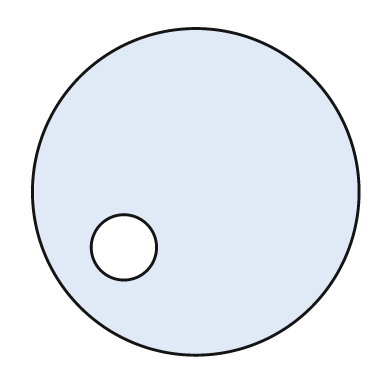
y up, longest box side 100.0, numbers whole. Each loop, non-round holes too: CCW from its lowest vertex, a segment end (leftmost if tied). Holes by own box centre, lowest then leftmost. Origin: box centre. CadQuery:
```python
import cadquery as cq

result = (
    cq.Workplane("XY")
    .moveTo(0.0, 0.0)
    .circle(50.0)
    .moveTo(-22.0, -17.0)
    .circle(10.0)
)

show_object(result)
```